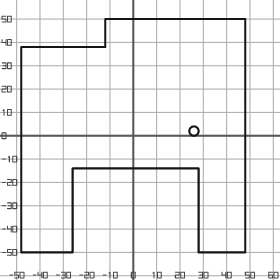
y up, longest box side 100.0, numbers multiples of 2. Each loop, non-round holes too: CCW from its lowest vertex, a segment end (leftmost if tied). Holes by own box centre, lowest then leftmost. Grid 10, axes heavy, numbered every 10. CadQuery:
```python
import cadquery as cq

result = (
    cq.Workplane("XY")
    .moveTo(-48.0, -50.0)
    .lineTo(-26.0, -50.0)
    .lineTo(-26.0, -14.0)
    .lineTo(28.0, -14.0)
    .lineTo(28.0, -50.0)
    .lineTo(48.0, -50.0)
    .lineTo(48.0, 50.0)
    .lineTo(-12.0, 50.0)
    .lineTo(-12.0, 38.0)
    .lineTo(-48.0, 38.0)
    .close()
    .moveTo(26.0, 2.0)
    .circle(2.0)
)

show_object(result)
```